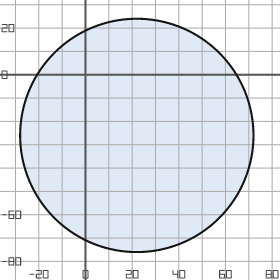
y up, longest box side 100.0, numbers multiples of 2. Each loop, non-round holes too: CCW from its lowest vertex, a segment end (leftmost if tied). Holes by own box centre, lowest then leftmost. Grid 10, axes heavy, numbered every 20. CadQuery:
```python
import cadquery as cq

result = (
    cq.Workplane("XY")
    .moveTo(22.0, -26.0)
    .circle(50.0)
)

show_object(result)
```